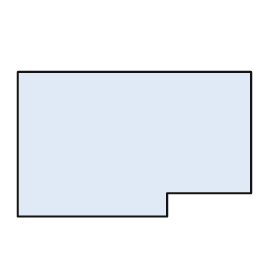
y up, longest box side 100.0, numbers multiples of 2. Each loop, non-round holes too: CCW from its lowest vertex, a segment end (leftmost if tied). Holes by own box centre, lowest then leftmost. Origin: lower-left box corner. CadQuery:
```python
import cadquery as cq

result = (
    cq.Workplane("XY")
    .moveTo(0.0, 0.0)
    .lineTo(64.0, 0.0)
    .lineTo(64.0, 10.0)
    .lineTo(100.0, 10.0)
    .lineTo(100.0, 62.0)
    .lineTo(0.0, 62.0)
    .close()
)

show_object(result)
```